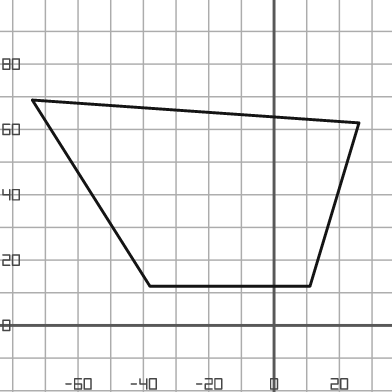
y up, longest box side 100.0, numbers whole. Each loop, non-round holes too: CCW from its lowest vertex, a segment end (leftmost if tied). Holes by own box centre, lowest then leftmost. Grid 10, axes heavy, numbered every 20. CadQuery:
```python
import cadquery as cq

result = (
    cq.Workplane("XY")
    .moveTo(-38.0, 12.0)
    .lineTo(11.0, 12.0)
    .lineTo(26.0, 62.0)
    .lineTo(-74.0, 69.0)
    .close()
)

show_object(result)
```